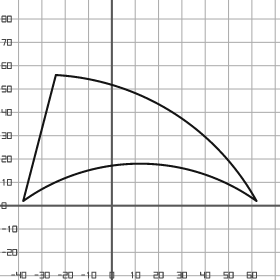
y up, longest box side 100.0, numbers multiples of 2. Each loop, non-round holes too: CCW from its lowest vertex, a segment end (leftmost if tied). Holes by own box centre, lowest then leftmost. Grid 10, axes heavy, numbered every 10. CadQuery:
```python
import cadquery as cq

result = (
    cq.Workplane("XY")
    .moveTo(-38.0, 2.0)
    .threePointArc((12.0, 18.0), (62.0, 2.0))
    .threePointArc((26.0, 40.0), (-24.0, 56.0))
    .close()
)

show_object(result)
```